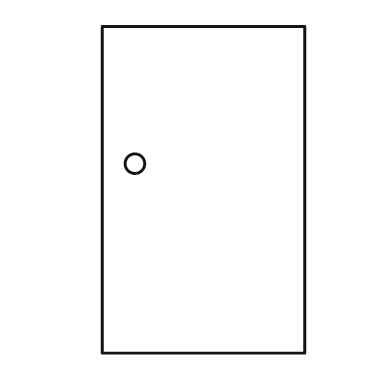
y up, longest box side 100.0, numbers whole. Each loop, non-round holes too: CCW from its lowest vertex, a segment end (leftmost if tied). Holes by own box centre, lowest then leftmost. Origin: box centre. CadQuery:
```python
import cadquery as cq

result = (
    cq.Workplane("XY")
    .moveTo(-31.0, -50.0)
    .lineTo(31.0, -50.0)
    .lineTo(31.0, 50.0)
    .lineTo(-31.0, 50.0)
    .close()
    .moveTo(-21.0, 8.0)
    .circle(3.0)
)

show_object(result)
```